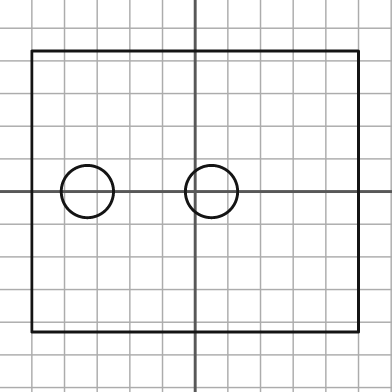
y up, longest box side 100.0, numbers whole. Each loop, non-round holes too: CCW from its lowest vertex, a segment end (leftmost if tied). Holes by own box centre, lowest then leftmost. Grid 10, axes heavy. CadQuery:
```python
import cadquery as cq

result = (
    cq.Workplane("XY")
    .moveTo(-50.0, -43.0)
    .lineTo(50.0, -43.0)
    .lineTo(50.0, 43.0)
    .lineTo(-50.0, 43.0)
    .close()
    .moveTo(-33.0, 0.0)
    .circle(8.0)
    .moveTo(5.0, 0.0)
    .circle(8.0)
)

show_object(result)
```